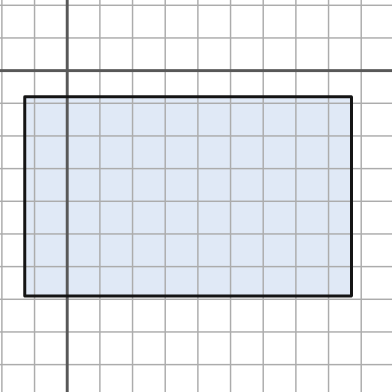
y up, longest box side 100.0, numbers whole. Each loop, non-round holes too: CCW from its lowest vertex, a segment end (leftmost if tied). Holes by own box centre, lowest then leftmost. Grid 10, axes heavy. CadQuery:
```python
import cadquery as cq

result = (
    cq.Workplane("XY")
    .moveTo(-13.0, -69.0)
    .lineTo(87.0, -69.0)
    .lineTo(87.0, -8.0)
    .lineTo(-13.0, -8.0)
    .close()
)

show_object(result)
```